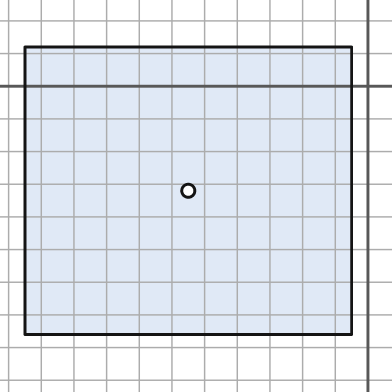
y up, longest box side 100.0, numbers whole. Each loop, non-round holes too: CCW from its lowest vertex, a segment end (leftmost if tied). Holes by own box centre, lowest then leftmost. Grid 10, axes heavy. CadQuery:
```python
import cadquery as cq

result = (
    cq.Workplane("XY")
    .moveTo(-105.0, -76.0)
    .lineTo(-5.0, -76.0)
    .lineTo(-5.0, 12.0)
    .lineTo(-105.0, 12.0)
    .close()
    .moveTo(-55.0, -32.0)
    .circle(2.0)
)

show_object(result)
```